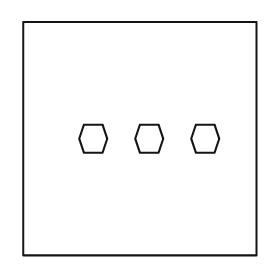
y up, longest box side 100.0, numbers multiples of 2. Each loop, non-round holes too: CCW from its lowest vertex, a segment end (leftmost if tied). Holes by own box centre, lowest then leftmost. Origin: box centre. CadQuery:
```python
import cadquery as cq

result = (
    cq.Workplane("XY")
    .moveTo(-50.0, -50.0)
    .lineTo(50.0, -50.0)
    .lineTo(50.0, 50.0)
    .lineTo(-50.0, 50.0)
    .close()
    .moveTo(-24.0, -6.0)
    .lineTo(-16.0, -6.0)
    .lineTo(-14.0, 0.0)
    .lineTo(-16.0, 6.0)
    .lineTo(-24.0, 6.0)
    .lineTo(-26.0, 0.0)
    .close()
    .moveTo(0.0, -6.0)
    .lineTo(8.0, -6.0)
    .lineTo(10.0, 0.0)
    .lineTo(8.0, 6.0)
    .lineTo(0.0, 6.0)
    .lineTo(-2.0, 0.0)
    .close()
    .moveTo(24.0, -6.0)
    .lineTo(32.0, -6.0)
    .lineTo(34.0, 0.0)
    .lineTo(32.0, 6.0)
    .lineTo(24.0, 6.0)
    .lineTo(22.0, 0.0)
    .close()
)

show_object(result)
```